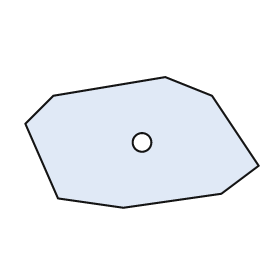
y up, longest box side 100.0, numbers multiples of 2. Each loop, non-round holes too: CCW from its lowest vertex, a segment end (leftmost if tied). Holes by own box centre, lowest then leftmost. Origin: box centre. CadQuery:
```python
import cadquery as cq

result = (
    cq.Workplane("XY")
    .moveTo(-8.0, -28.0)
    .lineTo(34.0, -22.0)
    .lineTo(50.0, -10.0)
    .lineTo(30.0, 20.0)
    .lineTo(10.0, 28.0)
    .lineTo(-38.0, 20.0)
    .lineTo(-50.0, 8.0)
    .lineTo(-36.0, -24.0)
    .close()
    .moveTo(0.0, 0.0)
    .circle(4.0)
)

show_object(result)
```